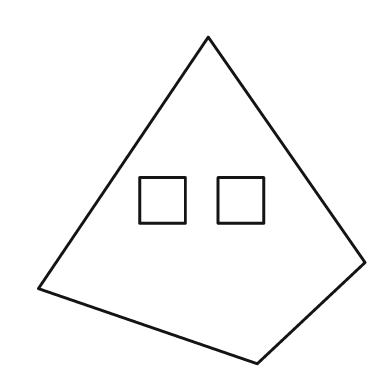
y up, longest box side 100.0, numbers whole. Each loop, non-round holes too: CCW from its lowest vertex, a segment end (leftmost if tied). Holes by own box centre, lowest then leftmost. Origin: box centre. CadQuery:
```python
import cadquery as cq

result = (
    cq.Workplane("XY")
    .moveTo(17.0, -50.0)
    .lineTo(50.0, -19.0)
    .lineTo(2.0, 50.0)
    .lineTo(-50.0, -27.0)
    .close()
    .moveTo(-19.0, -7.0)
    .lineTo(-5.0, -7.0)
    .lineTo(-5.0, 7.0)
    .lineTo(-19.0, 7.0)
    .close()
    .moveTo(5.0, -7.0)
    .lineTo(19.0, -7.0)
    .lineTo(19.0, 7.0)
    .lineTo(5.0, 7.0)
    .close()
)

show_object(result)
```